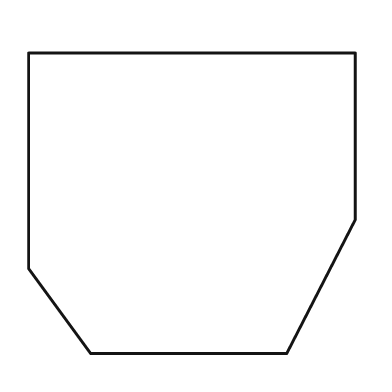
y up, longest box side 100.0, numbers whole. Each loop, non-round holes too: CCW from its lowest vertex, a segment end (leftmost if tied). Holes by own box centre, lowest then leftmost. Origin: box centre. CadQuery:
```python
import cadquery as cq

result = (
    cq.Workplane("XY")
    .moveTo(-31.0, -46.0)
    .lineTo(29.0, -46.0)
    .lineTo(50.0, -5.0)
    .lineTo(50.0, 46.0)
    .lineTo(-50.0, 46.0)
    .lineTo(-50.0, -20.0)
    .close()
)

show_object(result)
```